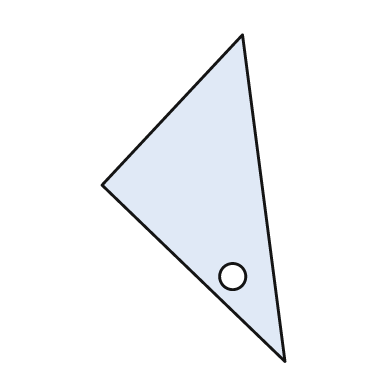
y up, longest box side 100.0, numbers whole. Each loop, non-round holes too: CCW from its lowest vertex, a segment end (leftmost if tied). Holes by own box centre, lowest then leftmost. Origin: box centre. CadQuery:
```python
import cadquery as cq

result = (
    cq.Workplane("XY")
    .moveTo(28.0, -50.0)
    .lineTo(15.0, 50.0)
    .lineTo(-28.0, 4.0)
    .close()
    .moveTo(12.0, -24.0)
    .circle(4.0)
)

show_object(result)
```